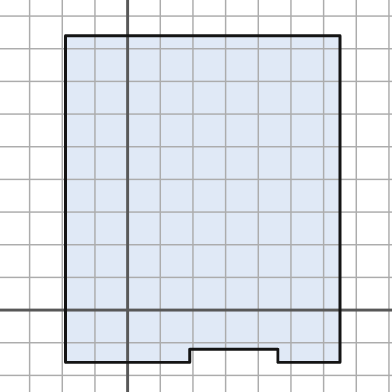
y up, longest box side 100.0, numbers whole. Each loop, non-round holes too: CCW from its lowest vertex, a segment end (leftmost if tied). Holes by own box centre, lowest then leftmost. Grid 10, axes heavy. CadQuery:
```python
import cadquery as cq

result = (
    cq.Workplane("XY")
    .moveTo(-19.0, -16.0)
    .lineTo(19.0, -16.0)
    .lineTo(19.0, -12.0)
    .lineTo(46.0, -12.0)
    .lineTo(46.0, -16.0)
    .lineTo(65.0, -16.0)
    .lineTo(65.0, 84.0)
    .lineTo(-19.0, 84.0)
    .close()
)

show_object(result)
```